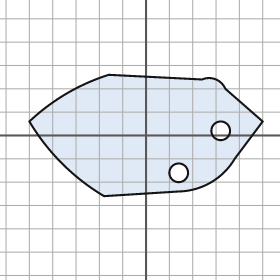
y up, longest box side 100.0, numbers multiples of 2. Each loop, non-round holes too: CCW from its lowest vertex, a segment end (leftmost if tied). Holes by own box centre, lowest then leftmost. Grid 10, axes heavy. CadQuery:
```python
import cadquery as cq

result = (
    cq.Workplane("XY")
    .moveTo(-18.0, -26.0)
    .lineTo(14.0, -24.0)
    .threePointArc((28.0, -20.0), (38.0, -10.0))
    .lineTo(50.0, 6.0)
    .lineTo(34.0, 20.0)
    .threePointArc((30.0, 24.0), (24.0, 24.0))
    .lineTo(-16.0, 26.0)
    .threePointArc((-34.0, 18.0), (-50.0, 6.0))
    .threePointArc((-36.0, -12.0), (-18.0, -26.0))
    .close()
    .moveTo(14.0, -16.0)
    .circle(4.0)
    .moveTo(32.0, 2.0)
    .circle(4.0)
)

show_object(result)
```